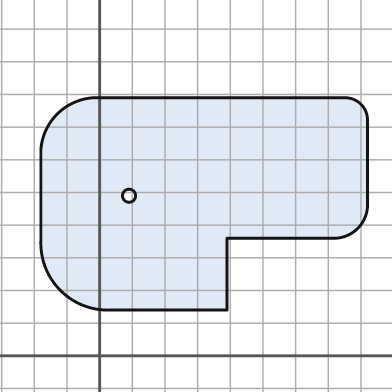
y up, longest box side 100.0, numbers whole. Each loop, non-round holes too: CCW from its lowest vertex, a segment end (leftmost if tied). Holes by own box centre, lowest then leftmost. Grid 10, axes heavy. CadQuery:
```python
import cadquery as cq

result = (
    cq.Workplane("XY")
    .moveTo(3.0, 14.0)
    .lineTo(39.0, 14.0)
    .lineTo(39.0, 36.0)
    .lineTo(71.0, 36.0)
    .threePointArc((79.0, 39.0), (82.0, 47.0))
    .lineTo(82.0, 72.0)
    .threePointArc((80.0, 77.0), (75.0, 79.0))
    .lineTo(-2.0, 79.0)
    .threePointArc((-13.0, 74.0), (-18.0, 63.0))
    .lineTo(-18.0, 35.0)
    .threePointArc((-12.0, 20.0), (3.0, 14.0))
    .close()
    .moveTo(9.0, 49.0)
    .circle(2.0)
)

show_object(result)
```